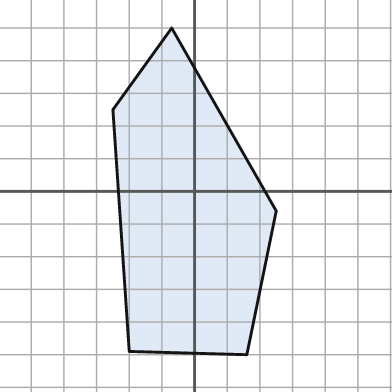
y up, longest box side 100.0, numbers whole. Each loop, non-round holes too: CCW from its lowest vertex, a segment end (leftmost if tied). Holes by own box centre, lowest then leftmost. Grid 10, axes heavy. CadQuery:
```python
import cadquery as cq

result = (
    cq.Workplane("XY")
    .moveTo(16.0, -50.0)
    .lineTo(25.0, -6.0)
    .lineTo(-7.0, 50.0)
    .lineTo(-25.0, 25.0)
    .lineTo(-20.0, -49.0)
    .close()
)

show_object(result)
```